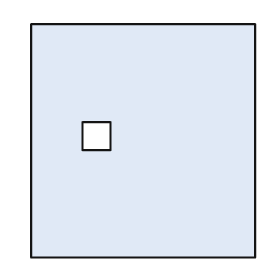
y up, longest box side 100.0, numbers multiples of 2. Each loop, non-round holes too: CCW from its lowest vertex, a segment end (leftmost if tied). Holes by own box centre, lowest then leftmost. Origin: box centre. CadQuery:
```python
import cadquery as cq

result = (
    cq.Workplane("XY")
    .moveTo(-48.0, -50.0)
    .lineTo(48.0, -50.0)
    .lineTo(48.0, 50.0)
    .lineTo(-48.0, 50.0)
    .close()
    .moveTo(-26.0, -4.0)
    .lineTo(-14.0, -4.0)
    .lineTo(-14.0, 8.0)
    .lineTo(-26.0, 8.0)
    .close()
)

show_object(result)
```